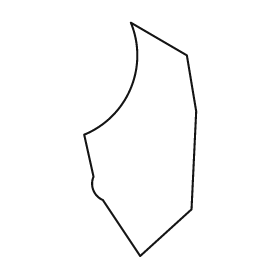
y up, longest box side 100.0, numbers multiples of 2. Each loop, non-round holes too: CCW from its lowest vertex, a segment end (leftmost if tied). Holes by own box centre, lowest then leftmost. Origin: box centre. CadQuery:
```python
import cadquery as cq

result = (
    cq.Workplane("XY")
    .moveTo(0.0, -50.0)
    .lineTo(22.0, -30.0)
    .lineTo(24.0, 12.0)
    .lineTo(20.0, 36.0)
    .lineTo(-4.0, 50.0)
    .threePointArc((-4.0, 22.0), (-24.0, 2.0))
    .lineTo(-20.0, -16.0)
    .threePointArc((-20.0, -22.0), (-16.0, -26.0))
    .close()
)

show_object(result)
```